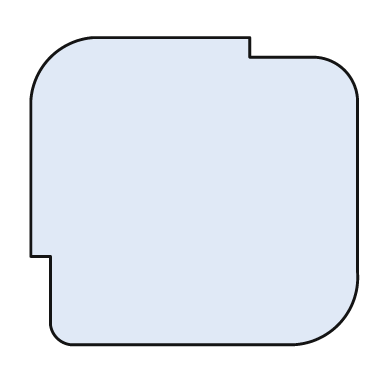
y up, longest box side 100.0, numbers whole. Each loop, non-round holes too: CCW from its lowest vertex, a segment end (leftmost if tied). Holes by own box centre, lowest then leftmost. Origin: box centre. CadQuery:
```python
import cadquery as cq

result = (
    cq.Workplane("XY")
    .moveTo(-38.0, -47.0)
    .lineTo(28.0, -47.0)
    .threePointArc((44.0, -41.0), (50.0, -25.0))
    .lineTo(50.0, 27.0)
    .threePointArc((46.0, 37.0), (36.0, 41.0))
    .lineTo(17.0, 41.0)
    .lineTo(17.0, 47.0)
    .lineTo(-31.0, 47.0)
    .threePointArc((-44.0, 41.0), (-50.0, 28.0))
    .lineTo(-50.0, -20.0)
    .lineTo(-44.0, -20.0)
    .lineTo(-44.0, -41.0)
    .threePointArc((-42.0, -45.0), (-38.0, -47.0))
    .close()
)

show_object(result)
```